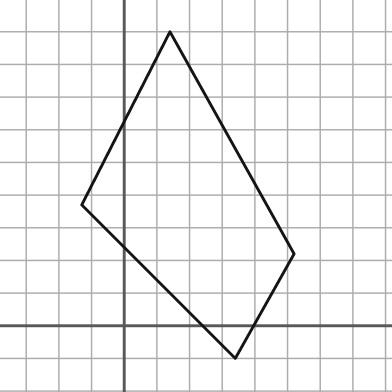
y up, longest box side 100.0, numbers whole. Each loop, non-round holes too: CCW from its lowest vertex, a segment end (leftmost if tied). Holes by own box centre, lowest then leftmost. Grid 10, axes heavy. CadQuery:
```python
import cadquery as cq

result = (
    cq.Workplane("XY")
    .moveTo(34.0, -10.0)
    .lineTo(52.0, 22.0)
    .lineTo(14.0, 90.0)
    .lineTo(-13.0, 37.0)
    .close()
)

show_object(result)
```